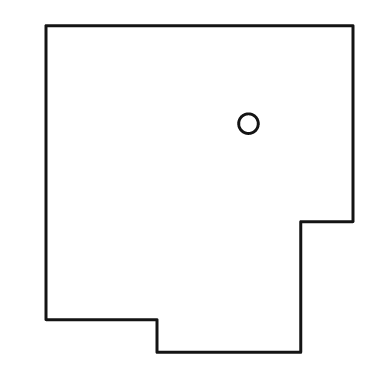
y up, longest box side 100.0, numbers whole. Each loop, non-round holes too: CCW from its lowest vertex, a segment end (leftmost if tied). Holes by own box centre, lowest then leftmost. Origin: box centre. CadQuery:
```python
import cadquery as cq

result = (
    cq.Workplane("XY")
    .moveTo(-13.0, -50.0)
    .lineTo(31.0, -50.0)
    .lineTo(31.0, -10.0)
    .lineTo(47.0, -10.0)
    .lineTo(47.0, 50.0)
    .lineTo(-47.0, 50.0)
    .lineTo(-47.0, -40.0)
    .lineTo(-13.0, -40.0)
    .close()
    .moveTo(15.0, 20.0)
    .circle(3.0)
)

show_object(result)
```